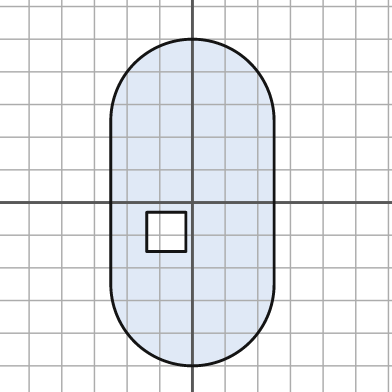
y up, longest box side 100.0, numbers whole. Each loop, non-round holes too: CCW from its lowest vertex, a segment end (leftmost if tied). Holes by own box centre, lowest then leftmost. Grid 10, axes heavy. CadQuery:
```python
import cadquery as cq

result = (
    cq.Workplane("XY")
    .moveTo(-25.0, -25.0)
    .threePointArc((0.0, -50.0), (25.0, -25.0))
    .lineTo(25.0, 25.0)
    .threePointArc((0.0, 50.0), (-25.0, 25.0))
    .close()
    .moveTo(-14.0, -15.0)
    .lineTo(-2.0, -15.0)
    .lineTo(-2.0, -3.0)
    .lineTo(-14.0, -3.0)
    .close()
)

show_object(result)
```